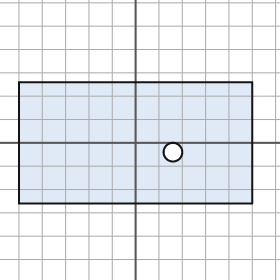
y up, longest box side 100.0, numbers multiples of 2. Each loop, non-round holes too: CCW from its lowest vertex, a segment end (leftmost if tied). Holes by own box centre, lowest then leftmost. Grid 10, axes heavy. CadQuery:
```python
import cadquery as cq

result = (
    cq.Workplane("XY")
    .moveTo(-50.0, -26.0)
    .lineTo(50.0, -26.0)
    .lineTo(50.0, 26.0)
    .lineTo(-50.0, 26.0)
    .close()
    .moveTo(16.0, -4.0)
    .circle(4.0)
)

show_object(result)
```